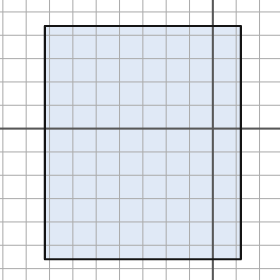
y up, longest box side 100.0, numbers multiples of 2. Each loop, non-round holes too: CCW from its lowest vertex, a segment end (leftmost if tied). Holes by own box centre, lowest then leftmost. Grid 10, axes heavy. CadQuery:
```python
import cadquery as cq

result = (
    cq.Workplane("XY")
    .moveTo(-72.0, -56.0)
    .lineTo(12.0, -56.0)
    .lineTo(12.0, 44.0)
    .lineTo(-72.0, 44.0)
    .close()
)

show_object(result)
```